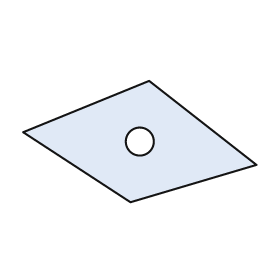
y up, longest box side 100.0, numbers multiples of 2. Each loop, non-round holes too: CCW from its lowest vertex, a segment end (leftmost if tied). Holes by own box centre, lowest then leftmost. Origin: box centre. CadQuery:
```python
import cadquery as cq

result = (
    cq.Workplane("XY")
    .moveTo(-4.0, -26.0)
    .lineTo(50.0, -10.0)
    .lineTo(4.0, 26.0)
    .lineTo(-50.0, 4.0)
    .close()
    .moveTo(0.0, 0.0)
    .circle(6.0)
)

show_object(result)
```